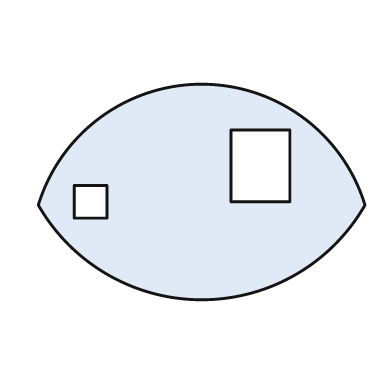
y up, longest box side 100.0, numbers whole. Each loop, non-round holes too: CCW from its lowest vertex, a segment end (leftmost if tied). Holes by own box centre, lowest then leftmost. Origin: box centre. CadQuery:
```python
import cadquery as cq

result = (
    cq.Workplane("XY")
    .moveTo(-50.0, -4.0)
    .threePointArc((0.0, -33.0), (50.0, -4.0))
    .threePointArc((0.0, 33.0), (-50.0, -4.0))
    .close()
    .moveTo(-39.0, -8.0)
    .lineTo(-29.0, -8.0)
    .lineTo(-29.0, 2.0)
    .lineTo(-39.0, 2.0)
    .close()
    .moveTo(9.0, -3.0)
    .lineTo(27.0, -3.0)
    .lineTo(27.0, 19.0)
    .lineTo(9.0, 19.0)
    .close()
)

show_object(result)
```